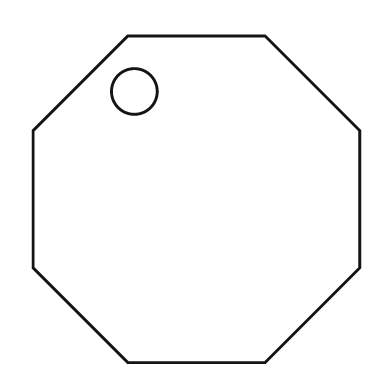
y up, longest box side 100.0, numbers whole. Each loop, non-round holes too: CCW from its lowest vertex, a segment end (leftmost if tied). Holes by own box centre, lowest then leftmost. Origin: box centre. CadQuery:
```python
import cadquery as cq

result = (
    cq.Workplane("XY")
    .moveTo(-21.0, -50.0)
    .lineTo(21.0, -50.0)
    .lineTo(50.0, -21.0)
    .lineTo(50.0, 21.0)
    .lineTo(21.0, 50.0)
    .lineTo(-21.0, 50.0)
    .lineTo(-50.0, 21.0)
    .lineTo(-50.0, -21.0)
    .close()
    .moveTo(-19.0, 33.0)
    .circle(7.0)
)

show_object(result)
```